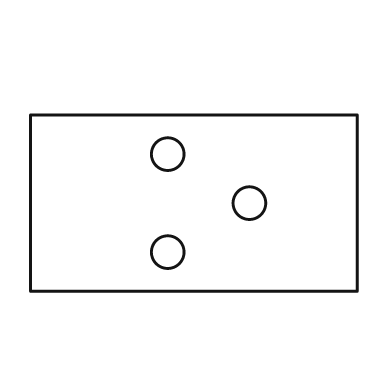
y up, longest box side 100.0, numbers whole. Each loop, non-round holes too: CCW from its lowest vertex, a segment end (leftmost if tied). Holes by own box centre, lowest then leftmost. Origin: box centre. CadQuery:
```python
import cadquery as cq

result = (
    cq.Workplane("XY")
    .moveTo(-50.0, -27.0)
    .lineTo(50.0, -27.0)
    .lineTo(50.0, 27.0)
    .lineTo(-50.0, 27.0)
    .close()
    .moveTo(-8.0, -15.0)
    .circle(5.0)
    .moveTo(17.0, 0.0)
    .circle(5.0)
    .moveTo(-8.0, 15.0)
    .circle(5.0)
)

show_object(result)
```